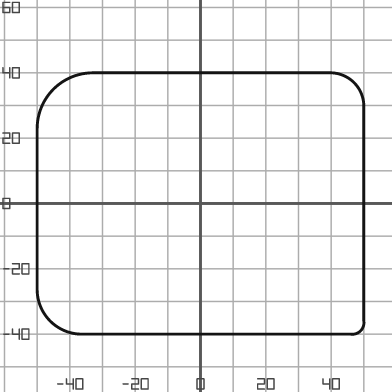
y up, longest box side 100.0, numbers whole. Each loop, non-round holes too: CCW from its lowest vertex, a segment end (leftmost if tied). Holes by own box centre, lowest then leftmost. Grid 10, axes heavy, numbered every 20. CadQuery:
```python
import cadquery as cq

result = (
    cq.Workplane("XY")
    .moveTo(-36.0, -40.0)
    .lineTo(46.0, -40.0)
    .threePointArc((49.0, -39.0), (50.0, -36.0))
    .lineTo(50.0, 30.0)
    .threePointArc((47.0, 37.0), (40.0, 40.0))
    .lineTo(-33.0, 40.0)
    .threePointArc((-45.0, 35.0), (-50.0, 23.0))
    .lineTo(-50.0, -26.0)
    .threePointArc((-46.0, -36.0), (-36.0, -40.0))
    .close()
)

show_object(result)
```